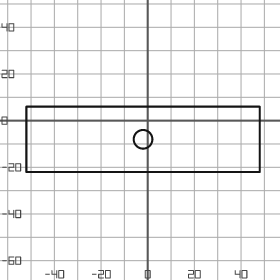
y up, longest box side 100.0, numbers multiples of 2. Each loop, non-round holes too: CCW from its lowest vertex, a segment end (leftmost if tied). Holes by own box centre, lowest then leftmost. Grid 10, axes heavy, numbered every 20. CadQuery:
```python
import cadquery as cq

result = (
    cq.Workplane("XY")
    .moveTo(-52.0, -22.0)
    .lineTo(48.0, -22.0)
    .lineTo(48.0, 6.0)
    .lineTo(-52.0, 6.0)
    .close()
    .moveTo(-2.0, -8.0)
    .circle(4.0)
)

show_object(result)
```